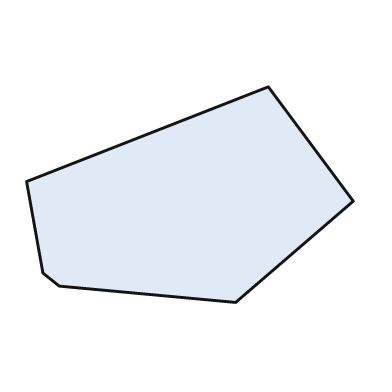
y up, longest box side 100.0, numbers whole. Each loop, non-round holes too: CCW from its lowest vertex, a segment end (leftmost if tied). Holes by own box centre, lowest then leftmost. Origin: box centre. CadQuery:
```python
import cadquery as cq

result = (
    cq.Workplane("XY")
    .moveTo(14.0, -33.0)
    .lineTo(50.0, -2.0)
    .lineTo(24.0, 33.0)
    .lineTo(-50.0, 4.0)
    .lineTo(-45.0, -24.0)
    .lineTo(-40.0, -28.0)
    .close()
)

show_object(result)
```